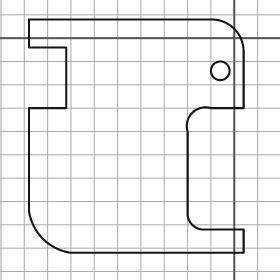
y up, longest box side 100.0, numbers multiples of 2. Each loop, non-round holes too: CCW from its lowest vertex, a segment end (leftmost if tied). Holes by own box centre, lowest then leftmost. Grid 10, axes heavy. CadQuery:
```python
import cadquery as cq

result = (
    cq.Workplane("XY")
    .moveTo(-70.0, -92.0)
    .lineTo(4.0, -92.0)
    .lineTo(4.0, -82.0)
    .lineTo(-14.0, -82.0)
    .threePointArc((-18.0, -80.0), (-20.0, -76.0))
    .lineTo(-20.0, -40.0)
    .threePointArc((-18.0, -32.0), (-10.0, -30.0))
    .lineTo(4.0, -30.0)
    .lineTo(4.0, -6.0)
    .threePointArc((0.0, 4.0), (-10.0, 8.0))
    .lineTo(-88.0, 8.0)
    .lineTo(-88.0, -4.0)
    .lineTo(-72.0, -4.0)
    .lineTo(-72.0, -30.0)
    .lineTo(-88.0, -30.0)
    .lineTo(-88.0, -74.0)
    .threePointArc((-82.0, -86.0), (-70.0, -92.0))
    .close()
    .moveTo(-6.0, -14.0)
    .circle(4.0)
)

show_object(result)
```